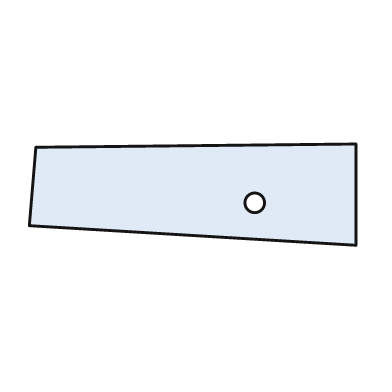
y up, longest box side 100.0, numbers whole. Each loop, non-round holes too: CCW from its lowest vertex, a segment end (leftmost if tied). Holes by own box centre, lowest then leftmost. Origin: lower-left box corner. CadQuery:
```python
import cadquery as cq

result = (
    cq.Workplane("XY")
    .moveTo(100.0, 0.0)
    .lineTo(100.0, 31.0)
    .lineTo(2.0, 30.0)
    .lineTo(0.0, 6.0)
    .close()
    .moveTo(69.0, 13.0)
    .circle(3.0)
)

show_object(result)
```